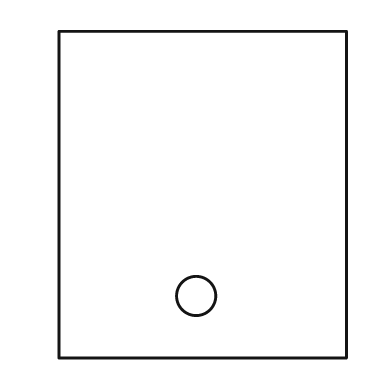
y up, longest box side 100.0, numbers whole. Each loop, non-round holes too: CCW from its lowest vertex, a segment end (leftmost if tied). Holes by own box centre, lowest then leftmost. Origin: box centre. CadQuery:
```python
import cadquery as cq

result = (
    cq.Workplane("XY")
    .moveTo(-44.0, -50.0)
    .lineTo(44.0, -50.0)
    .lineTo(44.0, 50.0)
    .lineTo(-44.0, 50.0)
    .close()
    .moveTo(-2.0, -31.0)
    .circle(6.0)
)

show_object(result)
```